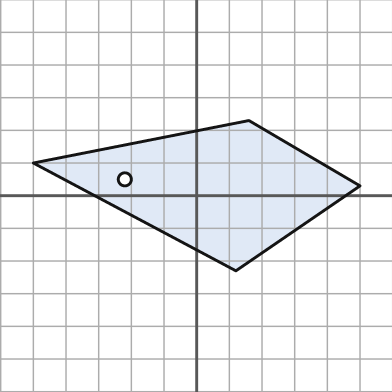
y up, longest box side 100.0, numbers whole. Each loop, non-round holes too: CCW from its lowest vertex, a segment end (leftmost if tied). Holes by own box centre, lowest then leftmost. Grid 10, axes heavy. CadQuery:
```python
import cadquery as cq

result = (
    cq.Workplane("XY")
    .moveTo(12.0, -23.0)
    .lineTo(50.0, 3.0)
    .lineTo(16.0, 23.0)
    .lineTo(-50.0, 10.0)
    .close()
    .moveTo(-22.0, 5.0)
    .circle(2.0)
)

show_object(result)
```